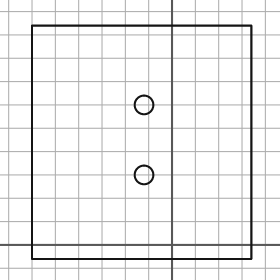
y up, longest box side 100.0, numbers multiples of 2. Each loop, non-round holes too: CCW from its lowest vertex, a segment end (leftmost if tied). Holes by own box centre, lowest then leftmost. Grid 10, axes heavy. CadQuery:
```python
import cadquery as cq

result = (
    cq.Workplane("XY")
    .moveTo(-60.0, -6.0)
    .lineTo(34.0, -6.0)
    .lineTo(34.0, 94.0)
    .lineTo(-60.0, 94.0)
    .close()
    .moveTo(-12.0, 30.0)
    .circle(4.0)
    .moveTo(-12.0, 60.0)
    .circle(4.0)
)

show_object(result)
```